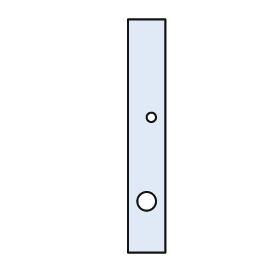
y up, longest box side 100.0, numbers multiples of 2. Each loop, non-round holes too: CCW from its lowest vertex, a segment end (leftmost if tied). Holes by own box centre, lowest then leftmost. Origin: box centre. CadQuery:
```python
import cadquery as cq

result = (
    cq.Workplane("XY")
    .moveTo(-8.0, -50.0)
    .lineTo(8.0, -50.0)
    .lineTo(8.0, 50.0)
    .lineTo(-8.0, 50.0)
    .close()
    .moveTo(0.0, -28.0)
    .circle(4.0)
    .moveTo(2.0, 8.0)
    .circle(2.0)
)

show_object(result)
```